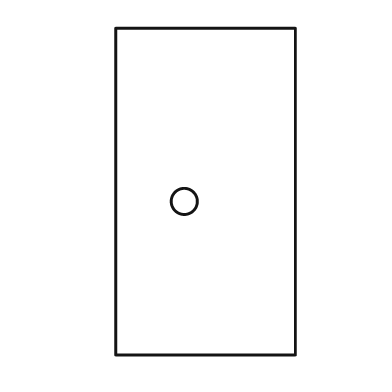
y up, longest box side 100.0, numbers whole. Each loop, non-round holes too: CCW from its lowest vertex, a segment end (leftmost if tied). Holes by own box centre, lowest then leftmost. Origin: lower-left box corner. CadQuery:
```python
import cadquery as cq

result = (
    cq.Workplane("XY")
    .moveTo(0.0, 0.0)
    .lineTo(55.0, 0.0)
    .lineTo(55.0, 100.0)
    .lineTo(0.0, 100.0)
    .close()
    .moveTo(21.0, 47.0)
    .circle(4.0)
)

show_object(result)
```